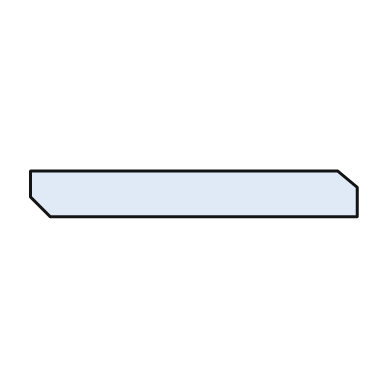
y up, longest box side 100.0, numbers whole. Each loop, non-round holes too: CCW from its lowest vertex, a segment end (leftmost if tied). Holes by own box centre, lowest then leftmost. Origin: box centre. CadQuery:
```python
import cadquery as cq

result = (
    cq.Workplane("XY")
    .moveTo(-44.0, -7.0)
    .lineTo(50.0, -7.0)
    .lineTo(50.0, 2.0)
    .lineTo(44.0, 7.0)
    .lineTo(-50.0, 7.0)
    .lineTo(-50.0, -1.0)
    .close()
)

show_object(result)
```